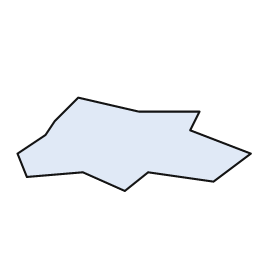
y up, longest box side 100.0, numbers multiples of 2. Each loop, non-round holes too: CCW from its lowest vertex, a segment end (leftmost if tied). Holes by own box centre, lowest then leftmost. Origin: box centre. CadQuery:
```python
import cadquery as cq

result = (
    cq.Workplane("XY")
    .moveTo(-4.0, -20.0)
    .lineTo(6.0, -12.0)
    .lineTo(34.0, -16.0)
    .lineTo(50.0, -4.0)
    .lineTo(24.0, 6.0)
    .lineTo(28.0, 14.0)
    .lineTo(2.0, 14.0)
    .lineTo(-24.0, 20.0)
    .lineTo(-34.0, 10.0)
    .lineTo(-38.0, 4.0)
    .lineTo(-50.0, -4.0)
    .lineTo(-46.0, -14.0)
    .lineTo(-22.0, -12.0)
    .close()
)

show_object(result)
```